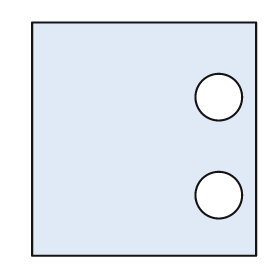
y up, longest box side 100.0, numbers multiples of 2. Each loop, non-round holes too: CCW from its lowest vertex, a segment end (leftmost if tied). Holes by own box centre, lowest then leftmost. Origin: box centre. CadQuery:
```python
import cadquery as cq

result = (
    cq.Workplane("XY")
    .moveTo(-48.0, -50.0)
    .lineTo(48.0, -50.0)
    .lineTo(48.0, 50.0)
    .lineTo(-48.0, 50.0)
    .close()
    .moveTo(32.0, -24.0)
    .circle(10.0)
    .moveTo(32.0, 18.0)
    .circle(10.0)
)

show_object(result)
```